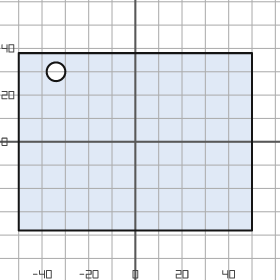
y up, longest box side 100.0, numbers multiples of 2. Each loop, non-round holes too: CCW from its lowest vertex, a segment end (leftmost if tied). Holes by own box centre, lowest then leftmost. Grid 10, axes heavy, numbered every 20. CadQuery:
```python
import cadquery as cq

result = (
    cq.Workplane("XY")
    .moveTo(-50.0, -38.0)
    .lineTo(50.0, -38.0)
    .lineTo(50.0, 38.0)
    .lineTo(-50.0, 38.0)
    .close()
    .moveTo(-34.0, 30.0)
    .circle(4.0)
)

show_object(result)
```